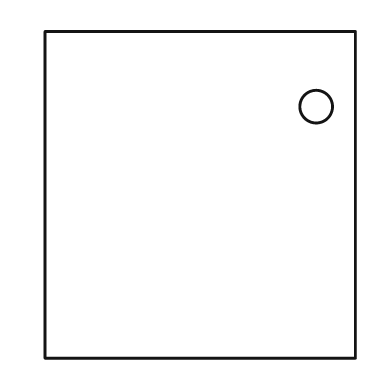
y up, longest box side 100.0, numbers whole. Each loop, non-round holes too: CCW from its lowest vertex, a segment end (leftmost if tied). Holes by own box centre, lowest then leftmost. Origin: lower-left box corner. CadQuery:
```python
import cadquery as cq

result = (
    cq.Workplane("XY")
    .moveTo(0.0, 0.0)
    .lineTo(95.0, 0.0)
    .lineTo(95.0, 100.0)
    .lineTo(0.0, 100.0)
    .close()
    .moveTo(83.0, 77.0)
    .circle(5.0)
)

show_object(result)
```